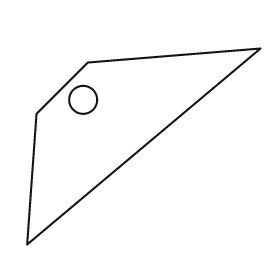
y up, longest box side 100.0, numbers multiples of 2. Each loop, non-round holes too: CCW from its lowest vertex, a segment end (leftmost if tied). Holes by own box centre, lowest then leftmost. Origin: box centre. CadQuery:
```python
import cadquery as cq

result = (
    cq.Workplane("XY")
    .moveTo(-50.0, -42.0)
    .lineTo(50.0, 42.0)
    .lineTo(-24.0, 36.0)
    .lineTo(-46.0, 14.0)
    .close()
    .moveTo(-26.0, 20.0)
    .circle(6.0)
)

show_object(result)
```